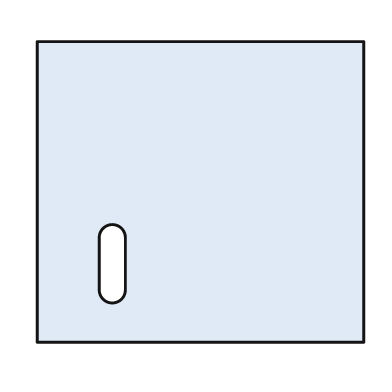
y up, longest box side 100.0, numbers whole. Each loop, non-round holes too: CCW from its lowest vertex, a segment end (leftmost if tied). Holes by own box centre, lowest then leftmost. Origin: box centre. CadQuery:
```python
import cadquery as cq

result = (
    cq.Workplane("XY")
    .moveTo(-50.0, -46.0)
    .lineTo(50.0, -46.0)
    .lineTo(50.0, 46.0)
    .lineTo(-50.0, 46.0)
    .close()
    .moveTo(-31.0, -30.0)
    .threePointArc((-27.0, -34.0), (-23.0, -30.0))
    .lineTo(-23.0, -14.0)
    .threePointArc((-27.0, -10.0), (-31.0, -14.0))
    .close()
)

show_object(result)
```